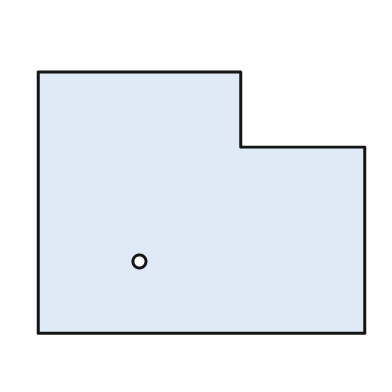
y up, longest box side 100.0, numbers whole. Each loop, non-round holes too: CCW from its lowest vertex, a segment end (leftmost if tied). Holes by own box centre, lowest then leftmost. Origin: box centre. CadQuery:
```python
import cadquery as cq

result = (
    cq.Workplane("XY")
    .moveTo(-50.0, -40.0)
    .lineTo(50.0, -40.0)
    .lineTo(50.0, 17.0)
    .lineTo(12.0, 17.0)
    .lineTo(12.0, 40.0)
    .lineTo(-50.0, 40.0)
    .close()
    .moveTo(-19.0, -18.0)
    .circle(2.0)
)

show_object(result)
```